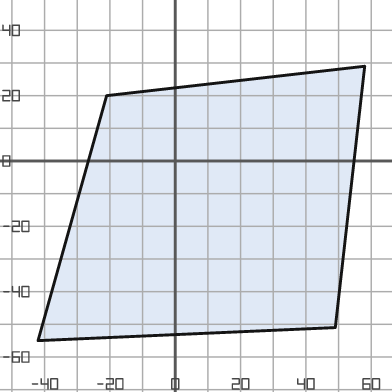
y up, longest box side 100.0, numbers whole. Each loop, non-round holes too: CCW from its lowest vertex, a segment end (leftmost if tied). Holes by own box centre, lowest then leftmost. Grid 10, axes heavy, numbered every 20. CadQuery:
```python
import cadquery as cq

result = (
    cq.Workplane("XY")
    .moveTo(-42.0, -55.0)
    .lineTo(49.0, -51.0)
    .lineTo(58.0, 29.0)
    .lineTo(-21.0, 20.0)
    .close()
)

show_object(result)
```